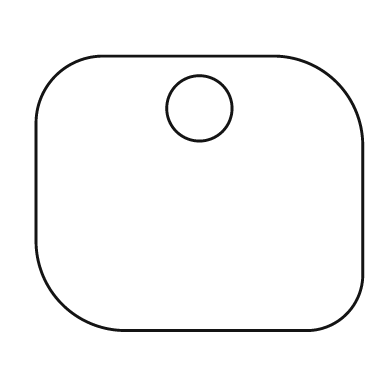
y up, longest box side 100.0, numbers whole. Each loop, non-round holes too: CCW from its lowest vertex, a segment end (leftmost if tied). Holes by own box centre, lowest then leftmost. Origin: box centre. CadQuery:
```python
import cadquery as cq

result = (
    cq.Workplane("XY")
    .moveTo(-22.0, -42.0)
    .lineTo(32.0, -42.0)
    .threePointArc((45.0, -37.0), (50.0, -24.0))
    .lineTo(50.0, 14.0)
    .threePointArc((42.0, 34.0), (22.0, 42.0))
    .lineTo(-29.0, 42.0)
    .threePointArc((-44.0, 36.0), (-50.0, 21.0))
    .lineTo(-50.0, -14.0)
    .threePointArc((-42.0, -34.0), (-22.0, -42.0))
    .close()
    .moveTo(0.0, 26.0)
    .circle(10.0)
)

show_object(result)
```